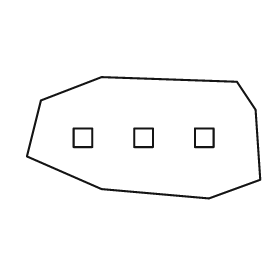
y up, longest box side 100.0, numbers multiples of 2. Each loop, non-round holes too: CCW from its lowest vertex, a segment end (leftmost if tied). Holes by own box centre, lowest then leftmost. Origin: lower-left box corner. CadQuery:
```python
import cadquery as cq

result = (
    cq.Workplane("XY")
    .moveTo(78.0, 0.0)
    .lineTo(100.0, 8.0)
    .lineTo(98.0, 38.0)
    .lineTo(90.0, 50.0)
    .lineTo(32.0, 52.0)
    .lineTo(6.0, 42.0)
    .lineTo(0.0, 18.0)
    .lineTo(32.0, 4.0)
    .close()
    .moveTo(20.0, 22.0)
    .lineTo(28.0, 22.0)
    .lineTo(28.0, 30.0)
    .lineTo(20.0, 30.0)
    .close()
    .moveTo(46.0, 22.0)
    .lineTo(54.0, 22.0)
    .lineTo(54.0, 30.0)
    .lineTo(46.0, 30.0)
    .close()
    .moveTo(72.0, 22.0)
    .lineTo(80.0, 22.0)
    .lineTo(80.0, 30.0)
    .lineTo(72.0, 30.0)
    .close()
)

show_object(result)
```